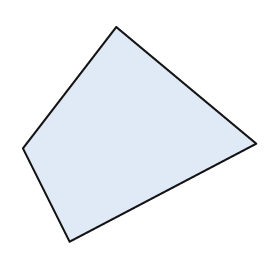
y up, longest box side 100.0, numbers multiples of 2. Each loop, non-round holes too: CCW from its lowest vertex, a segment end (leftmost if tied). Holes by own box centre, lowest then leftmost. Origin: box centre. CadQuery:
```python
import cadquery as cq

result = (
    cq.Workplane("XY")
    .moveTo(-30.0, -46.0)
    .lineTo(50.0, -4.0)
    .lineTo(-10.0, 46.0)
    .lineTo(-50.0, -6.0)
    .close()
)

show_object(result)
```